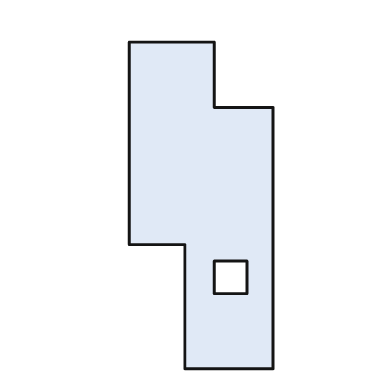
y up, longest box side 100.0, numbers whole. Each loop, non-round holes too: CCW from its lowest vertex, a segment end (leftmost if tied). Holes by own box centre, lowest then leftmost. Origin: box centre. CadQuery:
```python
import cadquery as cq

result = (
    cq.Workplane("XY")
    .moveTo(-5.0, -50.0)
    .lineTo(22.0, -50.0)
    .lineTo(22.0, 30.0)
    .lineTo(4.0, 30.0)
    .lineTo(4.0, 50.0)
    .lineTo(-22.0, 50.0)
    .lineTo(-22.0, -12.0)
    .lineTo(-5.0, -12.0)
    .close()
    .moveTo(4.0, -27.0)
    .lineTo(14.0, -27.0)
    .lineTo(14.0, -17.0)
    .lineTo(4.0, -17.0)
    .close()
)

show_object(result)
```